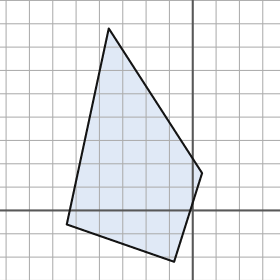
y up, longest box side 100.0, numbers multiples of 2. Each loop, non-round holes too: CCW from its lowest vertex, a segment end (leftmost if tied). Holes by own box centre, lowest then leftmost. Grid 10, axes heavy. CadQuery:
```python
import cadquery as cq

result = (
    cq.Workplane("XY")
    .moveTo(-8.0, -22.0)
    .lineTo(4.0, 16.0)
    .lineTo(-36.0, 78.0)
    .lineTo(-54.0, -6.0)
    .close()
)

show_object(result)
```